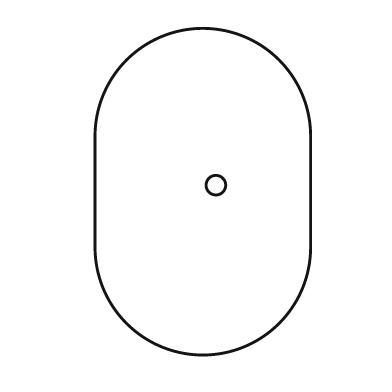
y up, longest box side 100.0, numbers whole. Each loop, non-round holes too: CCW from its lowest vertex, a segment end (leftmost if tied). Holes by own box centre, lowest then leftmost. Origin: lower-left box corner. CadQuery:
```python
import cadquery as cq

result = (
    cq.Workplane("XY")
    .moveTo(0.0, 33.0)
    .threePointArc((33.0, 0.0), (66.0, 33.0))
    .lineTo(66.0, 67.0)
    .threePointArc((33.0, 100.0), (0.0, 67.0))
    .close()
    .moveTo(37.0, 52.0)
    .circle(3.0)
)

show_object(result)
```